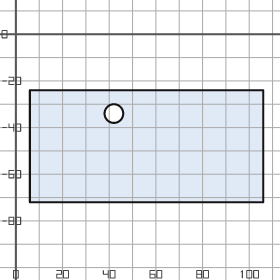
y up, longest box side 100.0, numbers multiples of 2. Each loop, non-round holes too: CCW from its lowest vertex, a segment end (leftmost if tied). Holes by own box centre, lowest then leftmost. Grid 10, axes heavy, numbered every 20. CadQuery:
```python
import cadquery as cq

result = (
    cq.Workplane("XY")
    .moveTo(6.0, -72.0)
    .lineTo(106.0, -72.0)
    .lineTo(106.0, -24.0)
    .lineTo(6.0, -24.0)
    .close()
    .moveTo(42.0, -34.0)
    .circle(4.0)
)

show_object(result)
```